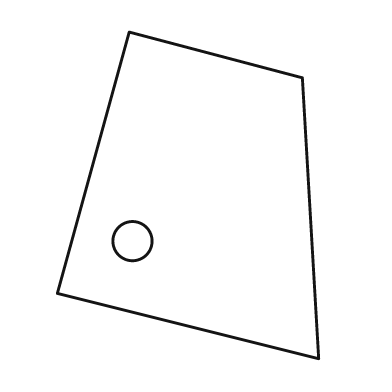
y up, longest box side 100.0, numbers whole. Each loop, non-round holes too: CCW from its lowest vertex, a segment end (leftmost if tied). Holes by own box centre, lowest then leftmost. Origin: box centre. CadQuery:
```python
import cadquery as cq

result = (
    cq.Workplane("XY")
    .moveTo(40.0, -50.0)
    .lineTo(35.0, 36.0)
    .lineTo(-18.0, 50.0)
    .lineTo(-40.0, -30.0)
    .close()
    .moveTo(-17.0, -14.0)
    .circle(6.0)
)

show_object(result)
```